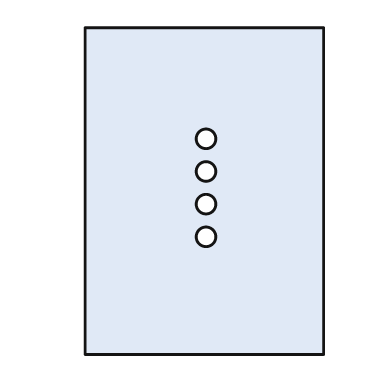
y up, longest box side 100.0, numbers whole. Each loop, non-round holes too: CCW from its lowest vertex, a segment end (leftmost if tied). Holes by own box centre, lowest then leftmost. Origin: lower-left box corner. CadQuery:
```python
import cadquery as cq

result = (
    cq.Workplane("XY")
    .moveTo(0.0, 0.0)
    .lineTo(73.0, 0.0)
    .lineTo(73.0, 100.0)
    .lineTo(0.0, 100.0)
    .close()
    .moveTo(37.0, 36.0)
    .circle(3.0)
    .moveTo(37.0, 46.0)
    .circle(3.0)
    .moveTo(37.0, 56.0)
    .circle(3.0)
    .moveTo(37.0, 66.0)
    .circle(3.0)
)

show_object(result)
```